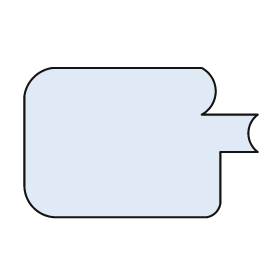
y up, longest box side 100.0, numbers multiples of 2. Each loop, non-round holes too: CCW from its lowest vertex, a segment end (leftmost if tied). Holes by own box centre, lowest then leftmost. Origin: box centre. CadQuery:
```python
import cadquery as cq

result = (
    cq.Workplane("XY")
    .moveTo(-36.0, -32.0)
    .lineTo(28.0, -32.0)
    .threePointArc((32.0, -30.0), (34.0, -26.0))
    .lineTo(34.0, -4.0)
    .lineTo(50.0, -4.0)
    .threePointArc((46.0, 4.0), (50.0, 12.0))
    .lineTo(26.0, 12.0)
    .threePointArc((32.0, 22.0), (26.0, 32.0))
    .lineTo(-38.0, 32.0)
    .threePointArc((-46.0, 28.0), (-50.0, 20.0))
    .lineTo(-50.0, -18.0)
    .threePointArc((-46.0, -28.0), (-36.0, -32.0))
    .close()
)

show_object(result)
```